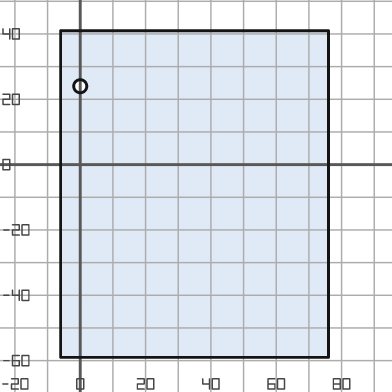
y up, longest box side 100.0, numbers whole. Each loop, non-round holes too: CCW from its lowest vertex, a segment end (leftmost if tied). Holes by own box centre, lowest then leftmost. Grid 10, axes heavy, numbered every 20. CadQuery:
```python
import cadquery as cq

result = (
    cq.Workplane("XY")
    .moveTo(-6.0, -59.0)
    .lineTo(76.0, -59.0)
    .lineTo(76.0, 41.0)
    .lineTo(-6.0, 41.0)
    .close()
    .moveTo(0.0, 24.0)
    .circle(2.0)
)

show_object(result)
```